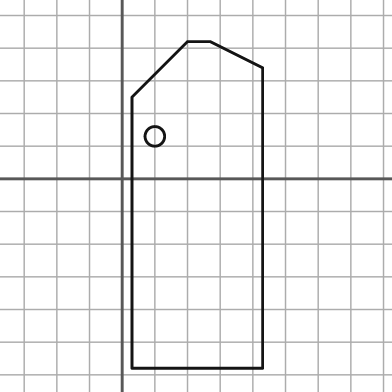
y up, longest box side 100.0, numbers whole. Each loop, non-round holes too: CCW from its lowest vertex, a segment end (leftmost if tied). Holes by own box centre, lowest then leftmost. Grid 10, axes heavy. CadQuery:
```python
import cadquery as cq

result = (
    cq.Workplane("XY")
    .moveTo(3.0, -58.0)
    .lineTo(43.0, -58.0)
    .lineTo(43.0, 34.0)
    .lineTo(27.0, 42.0)
    .lineTo(20.0, 42.0)
    .lineTo(3.0, 25.0)
    .close()
    .moveTo(10.0, 13.0)
    .circle(3.0)
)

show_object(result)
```